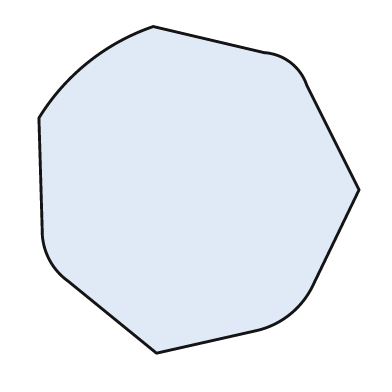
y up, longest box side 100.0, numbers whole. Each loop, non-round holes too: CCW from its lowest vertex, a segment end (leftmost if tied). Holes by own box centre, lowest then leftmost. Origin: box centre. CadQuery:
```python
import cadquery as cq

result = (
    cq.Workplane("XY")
    .moveTo(-13.0, -50.0)
    .lineTo(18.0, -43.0)
    .threePointArc((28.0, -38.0), (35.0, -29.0))
    .lineTo(49.0, 0.0)
    .lineTo(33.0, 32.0)
    .threePointArc((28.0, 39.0), (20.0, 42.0))
    .lineTo(-14.0, 50.0)
    .threePointArc((-34.0, 39.0), (-49.0, 22.0))
    .lineTo(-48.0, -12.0)
    .threePointArc((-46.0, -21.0), (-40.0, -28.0))
    .close()
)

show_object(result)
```